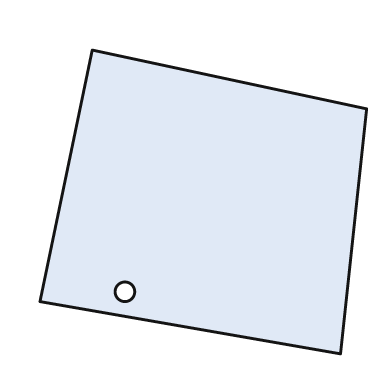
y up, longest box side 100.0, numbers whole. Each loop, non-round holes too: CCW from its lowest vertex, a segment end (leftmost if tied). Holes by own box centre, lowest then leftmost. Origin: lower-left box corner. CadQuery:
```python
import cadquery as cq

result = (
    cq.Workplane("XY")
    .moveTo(92.0, 0.0)
    .lineTo(100.0, 75.0)
    .lineTo(16.0, 93.0)
    .lineTo(0.0, 16.0)
    .close()
    .moveTo(26.0, 19.0)
    .circle(3.0)
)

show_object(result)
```